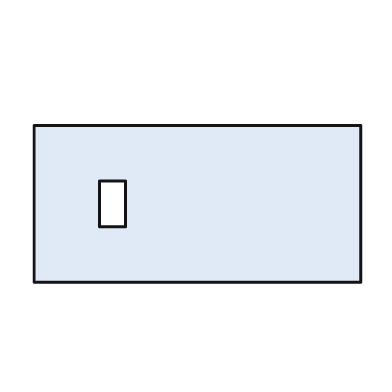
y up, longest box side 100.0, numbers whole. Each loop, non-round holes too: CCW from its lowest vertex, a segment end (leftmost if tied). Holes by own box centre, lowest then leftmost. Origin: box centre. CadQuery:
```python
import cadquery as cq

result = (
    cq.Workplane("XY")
    .moveTo(-50.0, -24.0)
    .lineTo(50.0, -24.0)
    .lineTo(50.0, 24.0)
    .lineTo(-50.0, 24.0)
    .close()
    .moveTo(-30.0, -7.0)
    .lineTo(-22.0, -7.0)
    .lineTo(-22.0, 7.0)
    .lineTo(-30.0, 7.0)
    .close()
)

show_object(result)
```